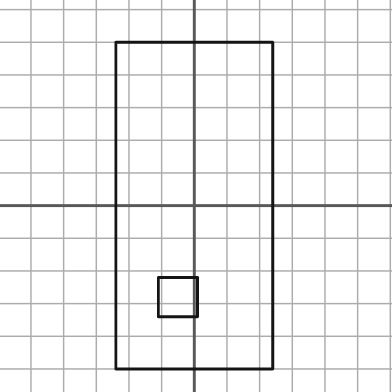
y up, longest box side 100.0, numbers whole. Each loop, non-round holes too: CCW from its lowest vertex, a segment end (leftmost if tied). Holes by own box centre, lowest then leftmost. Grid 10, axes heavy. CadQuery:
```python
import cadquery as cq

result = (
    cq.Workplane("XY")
    .moveTo(-24.0, -50.0)
    .lineTo(24.0, -50.0)
    .lineTo(24.0, 50.0)
    .lineTo(-24.0, 50.0)
    .close()
    .moveTo(-11.0, -34.0)
    .lineTo(1.0, -34.0)
    .lineTo(1.0, -22.0)
    .lineTo(-11.0, -22.0)
    .close()
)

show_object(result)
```